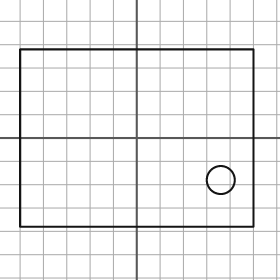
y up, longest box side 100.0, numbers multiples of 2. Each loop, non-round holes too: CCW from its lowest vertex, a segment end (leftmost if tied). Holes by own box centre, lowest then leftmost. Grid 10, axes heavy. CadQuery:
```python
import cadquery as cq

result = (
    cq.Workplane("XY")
    .moveTo(-50.0, -38.0)
    .lineTo(50.0, -38.0)
    .lineTo(50.0, 38.0)
    .lineTo(-50.0, 38.0)
    .close()
    .moveTo(36.0, -18.0)
    .circle(6.0)
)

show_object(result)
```